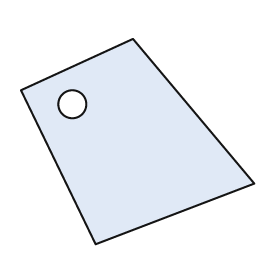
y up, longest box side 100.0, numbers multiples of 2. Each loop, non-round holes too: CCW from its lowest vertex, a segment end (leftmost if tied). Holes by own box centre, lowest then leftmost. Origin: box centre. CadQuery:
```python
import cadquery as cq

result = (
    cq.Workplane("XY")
    .moveTo(-18.0, -44.0)
    .lineTo(50.0, -18.0)
    .lineTo(-2.0, 44.0)
    .lineTo(-50.0, 22.0)
    .close()
    .moveTo(-28.0, 16.0)
    .circle(6.0)
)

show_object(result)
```